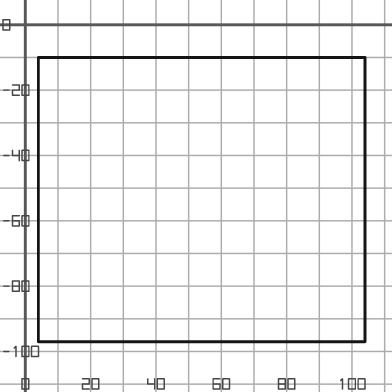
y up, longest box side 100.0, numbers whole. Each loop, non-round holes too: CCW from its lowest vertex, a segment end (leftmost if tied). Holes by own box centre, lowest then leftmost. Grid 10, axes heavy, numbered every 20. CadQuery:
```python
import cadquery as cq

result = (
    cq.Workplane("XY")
    .moveTo(4.0, -97.0)
    .lineTo(104.0, -97.0)
    .lineTo(104.0, -10.0)
    .lineTo(4.0, -10.0)
    .close()
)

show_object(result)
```